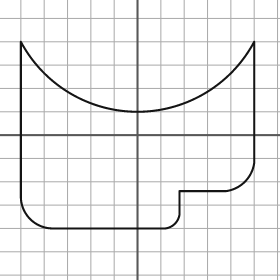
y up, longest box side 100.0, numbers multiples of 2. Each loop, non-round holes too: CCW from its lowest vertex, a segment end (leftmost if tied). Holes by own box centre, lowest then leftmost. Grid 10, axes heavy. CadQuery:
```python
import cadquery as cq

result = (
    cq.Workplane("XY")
    .moveTo(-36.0, -40.0)
    .lineTo(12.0, -40.0)
    .threePointArc((16.0, -38.0), (18.0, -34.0))
    .lineTo(18.0, -24.0)
    .lineTo(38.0, -24.0)
    .threePointArc((46.0, -20.0), (50.0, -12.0))
    .lineTo(50.0, 40.0)
    .threePointArc((0.0, 10.0), (-50.0, 40.0))
    .lineTo(-50.0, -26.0)
    .threePointArc((-46.0, -36.0), (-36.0, -40.0))
    .close()
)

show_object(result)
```